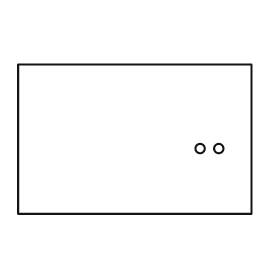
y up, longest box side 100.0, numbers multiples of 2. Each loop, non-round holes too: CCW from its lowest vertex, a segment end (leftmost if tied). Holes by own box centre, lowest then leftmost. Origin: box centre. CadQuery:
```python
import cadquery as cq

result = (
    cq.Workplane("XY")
    .moveTo(-50.0, -32.0)
    .lineTo(50.0, -32.0)
    .lineTo(50.0, 32.0)
    .lineTo(-50.0, 32.0)
    .close()
    .moveTo(28.0, -4.0)
    .circle(2.0)
    .moveTo(36.0, -4.0)
    .circle(2.0)
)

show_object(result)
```